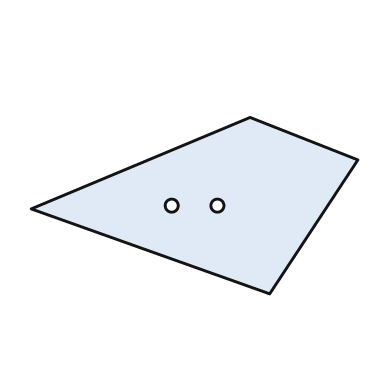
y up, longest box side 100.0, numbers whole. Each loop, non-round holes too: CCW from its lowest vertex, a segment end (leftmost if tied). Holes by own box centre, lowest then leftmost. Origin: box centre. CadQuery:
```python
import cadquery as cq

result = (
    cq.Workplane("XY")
    .moveTo(23.0, -27.0)
    .lineTo(50.0, 14.0)
    .lineTo(17.0, 27.0)
    .lineTo(-50.0, -1.0)
    .close()
    .moveTo(-7.0, 0.0)
    .circle(2.0)
    .moveTo(7.0, 0.0)
    .circle(2.0)
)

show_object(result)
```